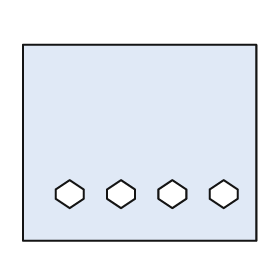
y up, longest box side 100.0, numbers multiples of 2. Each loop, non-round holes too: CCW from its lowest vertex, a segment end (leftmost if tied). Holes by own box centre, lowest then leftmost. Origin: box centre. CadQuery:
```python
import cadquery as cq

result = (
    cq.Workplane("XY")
    .moveTo(-50.0, -42.0)
    .lineTo(50.0, -42.0)
    .lineTo(50.0, 42.0)
    .lineTo(-50.0, 42.0)
    .close()
    .moveTo(-30.0, -28.0)
    .lineTo(-24.0, -24.0)
    .lineTo(-24.0, -20.0)
    .lineTo(-30.0, -16.0)
    .lineTo(-36.0, -20.0)
    .lineTo(-36.0, -24.0)
    .close()
    .moveTo(-8.0, -28.0)
    .lineTo(-2.0, -24.0)
    .lineTo(-2.0, -20.0)
    .lineTo(-8.0, -16.0)
    .lineTo(-14.0, -20.0)
    .lineTo(-14.0, -24.0)
    .close()
    .moveTo(14.0, -28.0)
    .lineTo(20.0, -24.0)
    .lineTo(20.0, -20.0)
    .lineTo(14.0, -16.0)
    .lineTo(8.0, -20.0)
    .lineTo(8.0, -24.0)
    .close()
    .moveTo(36.0, -28.0)
    .lineTo(42.0, -24.0)
    .lineTo(42.0, -20.0)
    .lineTo(36.0, -16.0)
    .lineTo(30.0, -20.0)
    .lineTo(30.0, -24.0)
    .close()
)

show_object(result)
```